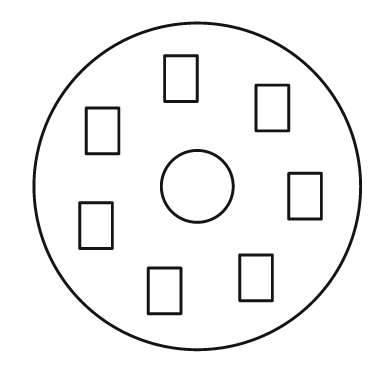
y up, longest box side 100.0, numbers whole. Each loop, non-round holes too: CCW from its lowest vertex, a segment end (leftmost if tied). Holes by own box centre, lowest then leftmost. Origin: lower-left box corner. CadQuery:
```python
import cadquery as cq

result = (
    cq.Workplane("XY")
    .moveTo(50.0, 50.0)
    .circle(50.0)
    .moveTo(35.0, 11.0)
    .lineTo(45.0, 11.0)
    .lineTo(45.0, 25.0)
    .lineTo(35.0, 25.0)
    .close()
    .moveTo(63.0, 15.0)
    .lineTo(73.0, 15.0)
    .lineTo(73.0, 29.0)
    .lineTo(63.0, 29.0)
    .close()
    .moveTo(14.0, 31.0)
    .lineTo(24.0, 31.0)
    .lineTo(24.0, 45.0)
    .lineTo(14.0, 45.0)
    .close()
    .moveTo(78.0, 40.0)
    .lineTo(88.0, 40.0)
    .lineTo(88.0, 54.0)
    .lineTo(78.0, 54.0)
    .close()
    .moveTo(50.0, 50.0)
    .circle(11.0)
    .moveTo(16.0, 60.0)
    .lineTo(26.0, 60.0)
    .lineTo(26.0, 74.0)
    .lineTo(16.0, 74.0)
    .close()
    .moveTo(68.0, 67.0)
    .lineTo(78.0, 67.0)
    .lineTo(78.0, 81.0)
    .lineTo(68.0, 81.0)
    .close()
    .moveTo(40.0, 76.0)
    .lineTo(50.0, 76.0)
    .lineTo(50.0, 90.0)
    .lineTo(40.0, 90.0)
    .close()
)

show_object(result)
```